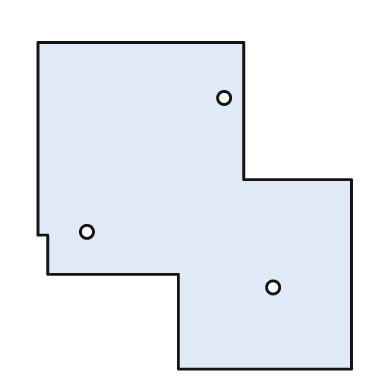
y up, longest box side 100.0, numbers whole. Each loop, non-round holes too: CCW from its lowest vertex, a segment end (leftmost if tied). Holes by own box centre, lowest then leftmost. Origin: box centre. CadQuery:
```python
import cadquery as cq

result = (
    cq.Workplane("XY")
    .moveTo(-5.0, -50.0)
    .lineTo(48.0, -50.0)
    .lineTo(48.0, 8.0)
    .lineTo(15.0, 8.0)
    .lineTo(15.0, 50.0)
    .lineTo(-48.0, 50.0)
    .lineTo(-48.0, -9.0)
    .lineTo(-45.0, -9.0)
    .lineTo(-45.0, -21.0)
    .lineTo(-5.0, -21.0)
    .close()
    .moveTo(24.0, -25.0)
    .circle(2.0)
    .moveTo(-33.0, -8.0)
    .circle(2.0)
    .moveTo(9.0, 33.0)
    .circle(2.0)
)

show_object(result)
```